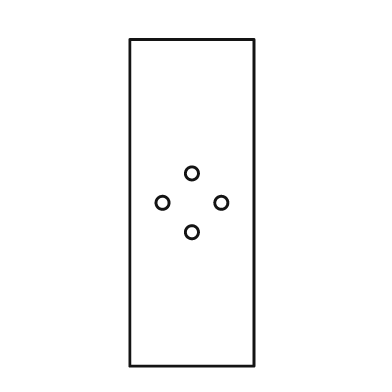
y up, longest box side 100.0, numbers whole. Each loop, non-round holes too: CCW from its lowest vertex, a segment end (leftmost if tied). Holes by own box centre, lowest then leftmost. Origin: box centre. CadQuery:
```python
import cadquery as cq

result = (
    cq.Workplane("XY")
    .moveTo(-19.0, -50.0)
    .lineTo(19.0, -50.0)
    .lineTo(19.0, 50.0)
    .lineTo(-19.0, 50.0)
    .close()
    .moveTo(0.0, -9.0)
    .circle(2.0)
    .moveTo(-9.0, 0.0)
    .circle(2.0)
    .moveTo(9.0, 0.0)
    .circle(2.0)
    .moveTo(0.0, 9.0)
    .circle(2.0)
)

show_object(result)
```